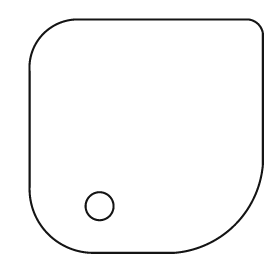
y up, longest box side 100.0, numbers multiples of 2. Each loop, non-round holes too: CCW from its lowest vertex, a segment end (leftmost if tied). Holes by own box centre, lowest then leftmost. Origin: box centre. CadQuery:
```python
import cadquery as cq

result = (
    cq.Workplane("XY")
    .moveTo(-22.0, -50.0)
    .lineTo(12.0, -50.0)
    .threePointArc((38.0, -38.0), (50.0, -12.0))
    .lineTo(50.0, 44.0)
    .threePointArc((48.0, 48.0), (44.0, 50.0))
    .lineTo(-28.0, 50.0)
    .threePointArc((-44.0, 44.0), (-50.0, 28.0))
    .lineTo(-50.0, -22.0)
    .threePointArc((-42.0, -42.0), (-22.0, -50.0))
    .close()
    .moveTo(-20.0, -30.0)
    .circle(6.0)
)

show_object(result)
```